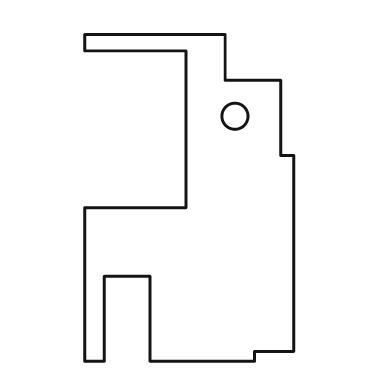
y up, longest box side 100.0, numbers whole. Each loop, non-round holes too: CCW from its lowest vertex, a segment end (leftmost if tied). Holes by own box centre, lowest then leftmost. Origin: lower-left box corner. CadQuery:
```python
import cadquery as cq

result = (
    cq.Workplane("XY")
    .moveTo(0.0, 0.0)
    .lineTo(6.0, 0.0)
    .lineTo(6.0, 26.0)
    .lineTo(20.0, 26.0)
    .lineTo(20.0, 0.0)
    .lineTo(52.0, 0.0)
    .lineTo(52.0, 3.0)
    .lineTo(64.0, 3.0)
    .lineTo(64.0, 63.0)
    .lineTo(60.0, 63.0)
    .lineTo(60.0, 86.0)
    .lineTo(43.0, 86.0)
    .lineTo(43.0, 100.0)
    .lineTo(0.0, 100.0)
    .lineTo(0.0, 95.0)
    .lineTo(31.0, 95.0)
    .lineTo(31.0, 47.0)
    .lineTo(0.0, 47.0)
    .close()
    .moveTo(46.0, 75.0)
    .circle(4.0)
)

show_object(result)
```